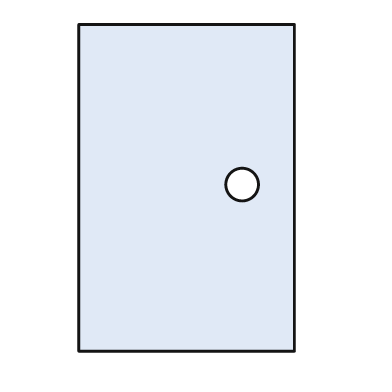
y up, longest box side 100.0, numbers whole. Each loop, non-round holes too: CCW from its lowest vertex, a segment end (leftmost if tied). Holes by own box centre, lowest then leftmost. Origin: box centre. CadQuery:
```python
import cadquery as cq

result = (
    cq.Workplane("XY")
    .moveTo(-33.0, -50.0)
    .lineTo(33.0, -50.0)
    .lineTo(33.0, 50.0)
    .lineTo(-33.0, 50.0)
    .close()
    .moveTo(17.0, 1.0)
    .circle(5.0)
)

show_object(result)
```